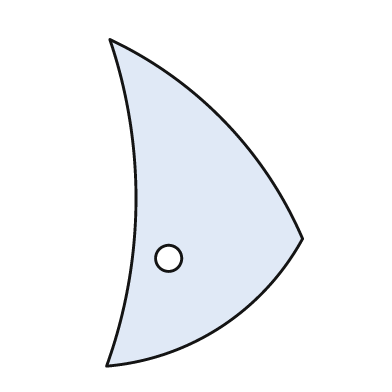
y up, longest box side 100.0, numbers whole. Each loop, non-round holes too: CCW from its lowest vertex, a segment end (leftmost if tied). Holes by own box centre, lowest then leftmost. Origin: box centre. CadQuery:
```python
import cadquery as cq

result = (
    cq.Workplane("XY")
    .moveTo(-30.0, -50.0)
    .threePointArc((5.0, -38.0), (30.0, -11.0))
    .threePointArc((6.0, 25.0), (-29.0, 50.0))
    .threePointArc((-21.0, 0.0), (-30.0, -50.0))
    .close()
    .moveTo(-11.0, -17.0)
    .circle(4.0)
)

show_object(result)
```